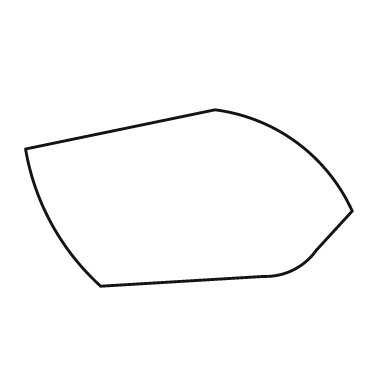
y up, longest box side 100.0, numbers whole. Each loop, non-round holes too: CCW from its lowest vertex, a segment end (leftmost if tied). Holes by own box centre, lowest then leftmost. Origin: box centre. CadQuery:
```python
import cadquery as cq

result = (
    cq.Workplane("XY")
    .moveTo(-27.0, -27.0)
    .lineTo(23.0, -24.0)
    .threePointArc((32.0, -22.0), (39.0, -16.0))
    .lineTo(50.0, -4.0)
    .threePointArc((33.0, 17.0), (8.0, 27.0))
    .lineTo(-50.0, 15.0)
    .threePointArc((-42.0, -8.0), (-27.0, -27.0))
    .close()
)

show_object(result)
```